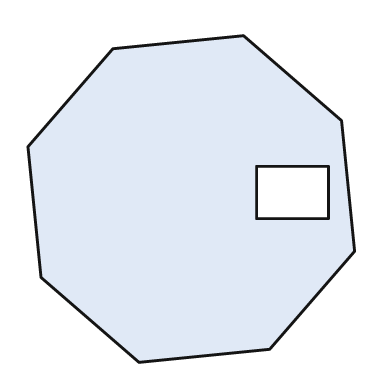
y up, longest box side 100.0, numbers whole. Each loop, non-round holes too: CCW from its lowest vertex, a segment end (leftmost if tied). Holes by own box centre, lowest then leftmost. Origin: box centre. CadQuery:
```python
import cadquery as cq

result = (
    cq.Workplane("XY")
    .moveTo(-16.0, -50.0)
    .lineTo(24.0, -46.0)
    .lineTo(50.0, -16.0)
    .lineTo(46.0, 24.0)
    .lineTo(16.0, 50.0)
    .lineTo(-24.0, 46.0)
    .lineTo(-50.0, 16.0)
    .lineTo(-46.0, -24.0)
    .close()
    .moveTo(20.0, -6.0)
    .lineTo(42.0, -6.0)
    .lineTo(42.0, 10.0)
    .lineTo(20.0, 10.0)
    .close()
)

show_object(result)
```